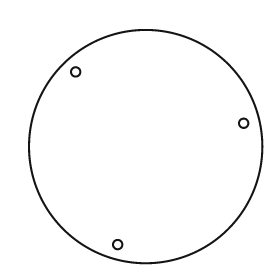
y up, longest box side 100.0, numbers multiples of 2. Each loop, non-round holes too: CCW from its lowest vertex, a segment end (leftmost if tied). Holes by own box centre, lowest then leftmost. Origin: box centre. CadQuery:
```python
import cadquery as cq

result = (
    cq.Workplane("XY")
    .moveTo(0.0, 0.0)
    .circle(50.0)
    .moveTo(-12.0, -42.0)
    .circle(2.0)
    .moveTo(42.0, 10.0)
    .circle(2.0)
    .moveTo(-30.0, 32.0)
    .circle(2.0)
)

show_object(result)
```